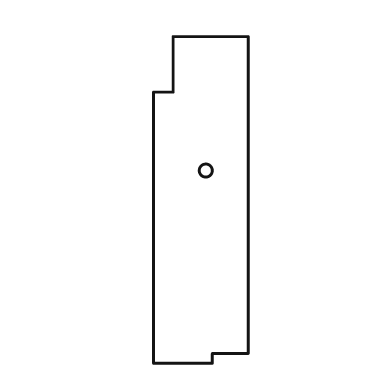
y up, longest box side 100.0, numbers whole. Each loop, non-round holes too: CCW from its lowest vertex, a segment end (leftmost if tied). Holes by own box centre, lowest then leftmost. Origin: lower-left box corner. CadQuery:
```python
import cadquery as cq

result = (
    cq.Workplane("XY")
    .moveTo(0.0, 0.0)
    .lineTo(18.0, 0.0)
    .lineTo(18.0, 3.0)
    .lineTo(29.0, 3.0)
    .lineTo(29.0, 100.0)
    .lineTo(6.0, 100.0)
    .lineTo(6.0, 83.0)
    .lineTo(0.0, 83.0)
    .close()
    .moveTo(16.0, 59.0)
    .circle(2.0)
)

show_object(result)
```